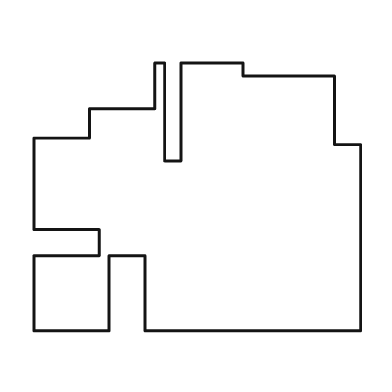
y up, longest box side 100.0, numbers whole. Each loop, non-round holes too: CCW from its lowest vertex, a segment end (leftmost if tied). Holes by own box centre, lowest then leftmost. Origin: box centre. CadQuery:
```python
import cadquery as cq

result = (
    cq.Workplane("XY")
    .moveTo(-50.0, -41.0)
    .lineTo(-27.0, -41.0)
    .lineTo(-27.0, -18.0)
    .lineTo(-16.0, -18.0)
    .lineTo(-16.0, -41.0)
    .lineTo(50.0, -41.0)
    .lineTo(50.0, 16.0)
    .lineTo(42.0, 16.0)
    .lineTo(42.0, 37.0)
    .lineTo(14.0, 37.0)
    .lineTo(14.0, 41.0)
    .lineTo(-5.0, 41.0)
    .lineTo(-5.0, 11.0)
    .lineTo(-10.0, 11.0)
    .lineTo(-10.0, 41.0)
    .lineTo(-13.0, 41.0)
    .lineTo(-13.0, 27.0)
    .lineTo(-33.0, 27.0)
    .lineTo(-33.0, 18.0)
    .lineTo(-50.0, 18.0)
    .lineTo(-50.0, -10.0)
    .lineTo(-30.0, -10.0)
    .lineTo(-30.0, -18.0)
    .lineTo(-50.0, -18.0)
    .close()
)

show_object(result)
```